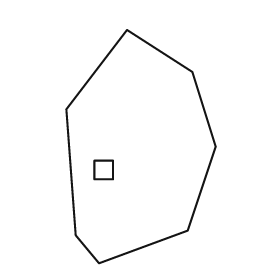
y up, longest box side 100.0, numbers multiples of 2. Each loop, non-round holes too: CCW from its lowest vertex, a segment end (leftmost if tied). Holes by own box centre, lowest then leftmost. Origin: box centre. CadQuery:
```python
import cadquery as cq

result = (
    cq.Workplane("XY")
    .moveTo(-18.0, -50.0)
    .lineTo(20.0, -36.0)
    .lineTo(32.0, 0.0)
    .lineTo(22.0, 32.0)
    .lineTo(-6.0, 50.0)
    .lineTo(-32.0, 16.0)
    .lineTo(-28.0, -38.0)
    .close()
    .moveTo(-20.0, -14.0)
    .lineTo(-12.0, -14.0)
    .lineTo(-12.0, -6.0)
    .lineTo(-20.0, -6.0)
    .close()
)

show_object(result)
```